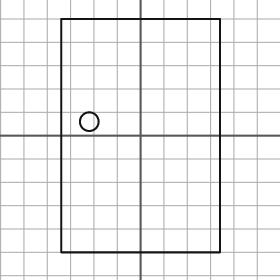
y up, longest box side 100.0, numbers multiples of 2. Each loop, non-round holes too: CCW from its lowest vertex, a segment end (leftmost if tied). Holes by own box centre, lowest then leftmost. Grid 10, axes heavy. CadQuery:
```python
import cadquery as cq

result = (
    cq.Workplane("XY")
    .moveTo(-34.0, -50.0)
    .lineTo(34.0, -50.0)
    .lineTo(34.0, 50.0)
    .lineTo(-34.0, 50.0)
    .close()
    .moveTo(-22.0, 6.0)
    .circle(4.0)
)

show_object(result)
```